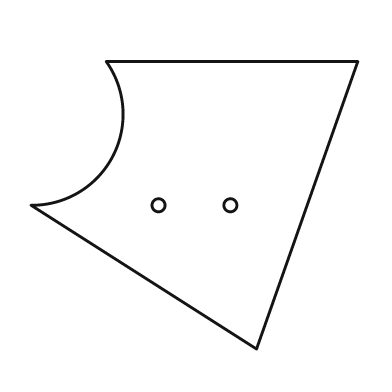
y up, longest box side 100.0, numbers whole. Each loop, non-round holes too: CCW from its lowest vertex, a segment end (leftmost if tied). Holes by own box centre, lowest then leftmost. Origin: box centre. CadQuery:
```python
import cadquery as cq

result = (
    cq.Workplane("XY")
    .moveTo(19.0, -44.0)
    .lineTo(50.0, 44.0)
    .lineTo(-27.0, 44.0)
    .threePointArc((-25.0, 15.0), (-50.0, 0.0))
    .close()
    .moveTo(-11.0, 0.0)
    .circle(2.0)
    .moveTo(11.0, 0.0)
    .circle(2.0)
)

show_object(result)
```